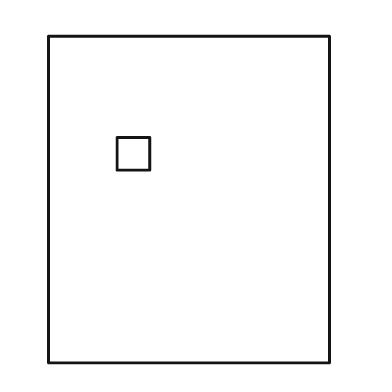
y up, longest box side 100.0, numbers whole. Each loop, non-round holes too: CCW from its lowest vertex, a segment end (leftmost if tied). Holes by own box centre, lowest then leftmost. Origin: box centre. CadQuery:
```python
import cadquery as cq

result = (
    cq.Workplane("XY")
    .moveTo(-43.0, -50.0)
    .lineTo(43.0, -50.0)
    .lineTo(43.0, 50.0)
    .lineTo(-43.0, 50.0)
    .close()
    .moveTo(-22.0, 9.0)
    .lineTo(-12.0, 9.0)
    .lineTo(-12.0, 19.0)
    .lineTo(-22.0, 19.0)
    .close()
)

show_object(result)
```